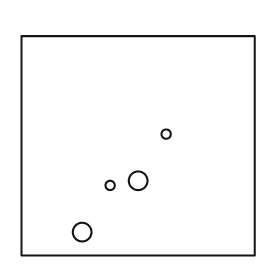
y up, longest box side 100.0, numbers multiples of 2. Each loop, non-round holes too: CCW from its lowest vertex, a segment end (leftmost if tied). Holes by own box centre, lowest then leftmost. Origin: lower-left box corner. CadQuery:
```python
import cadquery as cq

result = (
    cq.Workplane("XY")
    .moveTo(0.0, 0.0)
    .lineTo(100.0, 0.0)
    .lineTo(100.0, 94.0)
    .lineTo(0.0, 94.0)
    .close()
    .moveTo(26.0, 10.0)
    .circle(4.0)
    .moveTo(38.0, 30.0)
    .circle(2.0)
    .moveTo(50.0, 32.0)
    .circle(4.0)
    .moveTo(62.0, 52.0)
    .circle(2.0)
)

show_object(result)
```